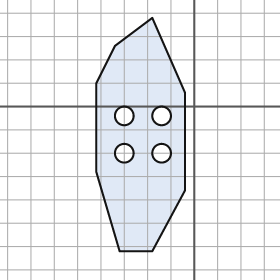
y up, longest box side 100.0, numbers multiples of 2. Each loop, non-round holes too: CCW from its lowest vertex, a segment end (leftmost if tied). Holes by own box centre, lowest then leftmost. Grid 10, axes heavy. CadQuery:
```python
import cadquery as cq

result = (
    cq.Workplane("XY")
    .moveTo(-32.0, -62.0)
    .lineTo(-18.0, -62.0)
    .lineTo(-4.0, -36.0)
    .lineTo(-4.0, 6.0)
    .lineTo(-18.0, 38.0)
    .lineTo(-34.0, 26.0)
    .lineTo(-42.0, 10.0)
    .lineTo(-42.0, -28.0)
    .close()
    .moveTo(-30.0, -20.0)
    .circle(4.0)
    .moveTo(-14.0, -20.0)
    .circle(4.0)
    .moveTo(-30.0, -4.0)
    .circle(4.0)
    .moveTo(-14.0, -4.0)
    .circle(4.0)
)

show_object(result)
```